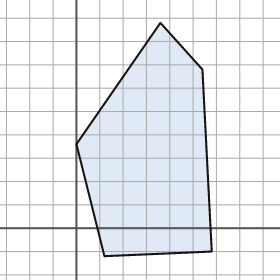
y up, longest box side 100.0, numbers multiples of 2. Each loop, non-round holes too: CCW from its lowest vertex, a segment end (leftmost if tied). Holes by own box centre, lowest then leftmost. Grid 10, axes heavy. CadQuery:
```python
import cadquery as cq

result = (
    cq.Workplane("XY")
    .moveTo(12.0, -12.0)
    .lineTo(58.0, -10.0)
    .lineTo(54.0, 68.0)
    .lineTo(36.0, 88.0)
    .lineTo(0.0, 36.0)
    .close()
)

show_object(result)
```